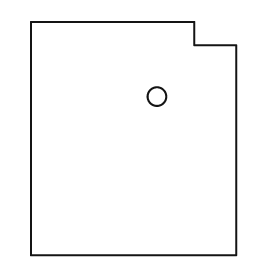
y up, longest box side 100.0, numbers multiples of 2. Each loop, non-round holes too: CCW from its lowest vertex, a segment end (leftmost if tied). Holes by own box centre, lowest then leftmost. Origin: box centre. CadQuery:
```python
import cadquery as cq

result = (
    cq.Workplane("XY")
    .moveTo(-44.0, -50.0)
    .lineTo(44.0, -50.0)
    .lineTo(44.0, 40.0)
    .lineTo(26.0, 40.0)
    .lineTo(26.0, 50.0)
    .lineTo(-44.0, 50.0)
    .close()
    .moveTo(10.0, 18.0)
    .circle(4.0)
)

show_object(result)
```